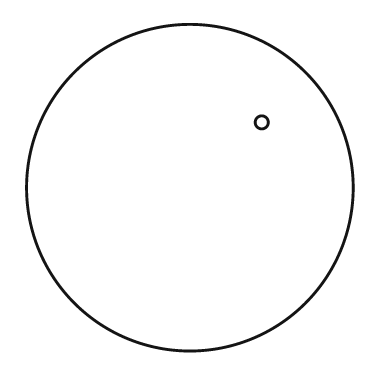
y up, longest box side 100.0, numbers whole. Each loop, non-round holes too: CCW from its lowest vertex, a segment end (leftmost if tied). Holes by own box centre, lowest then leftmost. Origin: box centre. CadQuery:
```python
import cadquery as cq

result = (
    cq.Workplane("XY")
    .moveTo(0.0, 0.0)
    .circle(50.0)
    .moveTo(22.0, 20.0)
    .circle(2.0)
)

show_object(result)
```